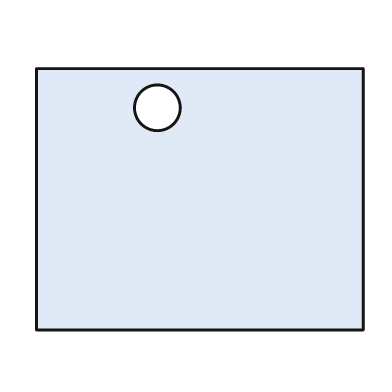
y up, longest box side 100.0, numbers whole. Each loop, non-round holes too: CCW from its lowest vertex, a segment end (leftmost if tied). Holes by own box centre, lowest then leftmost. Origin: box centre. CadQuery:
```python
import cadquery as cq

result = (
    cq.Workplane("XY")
    .moveTo(-50.0, -40.0)
    .lineTo(50.0, -40.0)
    .lineTo(50.0, 40.0)
    .lineTo(-50.0, 40.0)
    .close()
    .moveTo(-13.0, 28.0)
    .circle(7.0)
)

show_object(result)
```